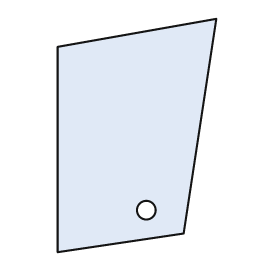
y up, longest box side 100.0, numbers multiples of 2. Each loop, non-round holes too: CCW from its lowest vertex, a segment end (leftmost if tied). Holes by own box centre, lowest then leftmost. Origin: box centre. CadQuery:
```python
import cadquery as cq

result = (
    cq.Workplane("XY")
    .moveTo(-34.0, -50.0)
    .lineTo(20.0, -42.0)
    .lineTo(34.0, 50.0)
    .lineTo(-34.0, 38.0)
    .close()
    .moveTo(4.0, -32.0)
    .circle(4.0)
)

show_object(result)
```